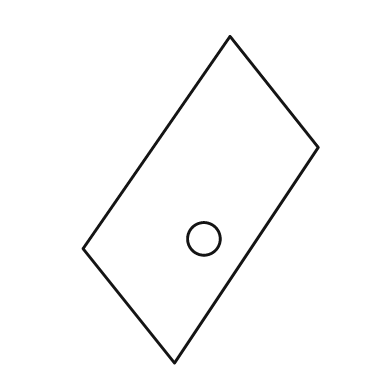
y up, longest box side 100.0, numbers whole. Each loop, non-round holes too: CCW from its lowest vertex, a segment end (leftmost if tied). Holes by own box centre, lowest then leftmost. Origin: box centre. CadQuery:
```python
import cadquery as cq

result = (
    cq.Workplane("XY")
    .moveTo(-8.0, -50.0)
    .lineTo(36.0, 16.0)
    .lineTo(9.0, 50.0)
    .lineTo(-36.0, -15.0)
    .close()
    .moveTo(1.0, -12.0)
    .circle(5.0)
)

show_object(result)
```